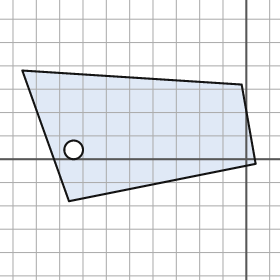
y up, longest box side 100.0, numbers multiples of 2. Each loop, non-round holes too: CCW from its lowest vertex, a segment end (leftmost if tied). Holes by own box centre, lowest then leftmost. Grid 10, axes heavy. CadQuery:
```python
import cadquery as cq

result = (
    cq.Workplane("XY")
    .moveTo(-76.0, -18.0)
    .lineTo(4.0, -2.0)
    .lineTo(-2.0, 32.0)
    .lineTo(-96.0, 38.0)
    .close()
    .moveTo(-74.0, 4.0)
    .circle(4.0)
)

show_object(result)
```